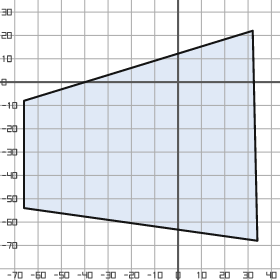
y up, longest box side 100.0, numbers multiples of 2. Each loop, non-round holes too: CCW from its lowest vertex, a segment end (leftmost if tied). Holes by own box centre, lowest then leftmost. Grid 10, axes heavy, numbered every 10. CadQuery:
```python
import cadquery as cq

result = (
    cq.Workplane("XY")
    .moveTo(34.0, -68.0)
    .lineTo(32.0, 22.0)
    .lineTo(-66.0, -8.0)
    .lineTo(-66.0, -54.0)
    .close()
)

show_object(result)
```